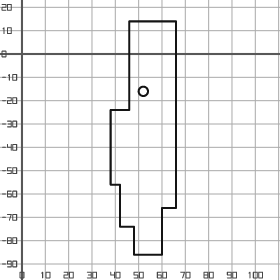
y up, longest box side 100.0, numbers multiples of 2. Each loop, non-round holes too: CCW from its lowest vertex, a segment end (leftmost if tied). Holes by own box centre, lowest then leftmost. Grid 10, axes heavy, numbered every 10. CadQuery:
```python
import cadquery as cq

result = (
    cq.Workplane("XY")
    .moveTo(48.0, -86.0)
    .lineTo(60.0, -86.0)
    .lineTo(60.0, -66.0)
    .lineTo(66.0, -66.0)
    .lineTo(66.0, 14.0)
    .lineTo(46.0, 14.0)
    .lineTo(46.0, -24.0)
    .lineTo(38.0, -24.0)
    .lineTo(38.0, -56.0)
    .lineTo(42.0, -56.0)
    .lineTo(42.0, -74.0)
    .lineTo(48.0, -74.0)
    .close()
    .moveTo(52.0, -16.0)
    .circle(2.0)
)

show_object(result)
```